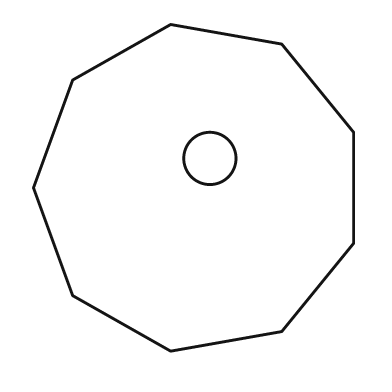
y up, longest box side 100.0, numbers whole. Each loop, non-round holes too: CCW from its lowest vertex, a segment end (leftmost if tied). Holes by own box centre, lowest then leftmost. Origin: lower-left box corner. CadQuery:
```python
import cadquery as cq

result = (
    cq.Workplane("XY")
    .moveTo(42.0, 0.0)
    .lineTo(76.0, 6.0)
    .lineTo(98.0, 33.0)
    .lineTo(98.0, 67.0)
    .lineTo(76.0, 94.0)
    .lineTo(42.0, 100.0)
    .lineTo(12.0, 83.0)
    .lineTo(0.0, 50.0)
    .lineTo(12.0, 17.0)
    .close()
    .moveTo(54.0, 59.0)
    .circle(8.0)
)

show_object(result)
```